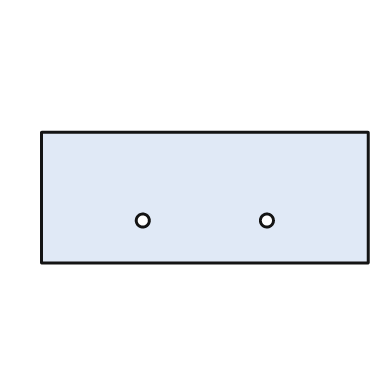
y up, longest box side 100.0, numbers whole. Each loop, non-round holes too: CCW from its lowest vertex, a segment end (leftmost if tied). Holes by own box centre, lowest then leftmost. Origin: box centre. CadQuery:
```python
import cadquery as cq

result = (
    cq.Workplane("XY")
    .moveTo(-50.0, -20.0)
    .lineTo(50.0, -20.0)
    .lineTo(50.0, 20.0)
    .lineTo(-50.0, 20.0)
    .close()
    .moveTo(-19.0, -7.0)
    .circle(2.0)
    .moveTo(19.0, -7.0)
    .circle(2.0)
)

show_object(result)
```